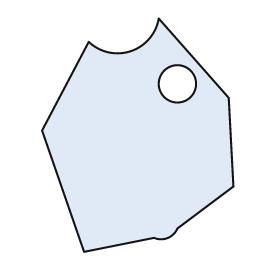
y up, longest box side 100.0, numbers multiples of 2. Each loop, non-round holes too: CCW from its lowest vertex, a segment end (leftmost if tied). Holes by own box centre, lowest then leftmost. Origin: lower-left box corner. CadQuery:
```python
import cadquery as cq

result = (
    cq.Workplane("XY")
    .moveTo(18.0, 0.0)
    .lineTo(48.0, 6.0)
    .threePointArc((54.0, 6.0), (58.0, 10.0))
    .lineTo(82.0, 28.0)
    .lineTo(80.0, 66.0)
    .lineTo(50.0, 100.0)
    .threePointArc((38.0, 86.0), (20.0, 90.0))
    .lineTo(0.0, 52.0)
    .close()
    .moveTo(58.0, 72.0)
    .circle(8.0)
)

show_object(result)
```